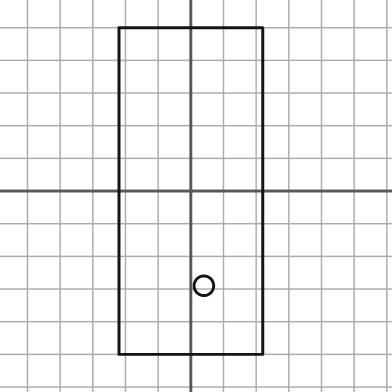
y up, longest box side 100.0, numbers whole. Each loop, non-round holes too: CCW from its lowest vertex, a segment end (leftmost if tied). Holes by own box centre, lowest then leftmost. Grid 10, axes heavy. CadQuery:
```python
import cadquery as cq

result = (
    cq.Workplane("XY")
    .moveTo(-22.0, -50.0)
    .lineTo(22.0, -50.0)
    .lineTo(22.0, 50.0)
    .lineTo(-22.0, 50.0)
    .close()
    .moveTo(4.0, -29.0)
    .circle(3.0)
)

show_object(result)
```